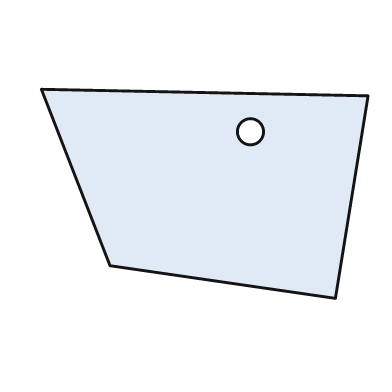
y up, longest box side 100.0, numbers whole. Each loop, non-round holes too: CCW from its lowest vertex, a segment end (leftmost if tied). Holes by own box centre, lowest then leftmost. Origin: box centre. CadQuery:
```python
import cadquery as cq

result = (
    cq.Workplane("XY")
    .moveTo(40.0, -32.0)
    .lineTo(50.0, 30.0)
    .lineTo(-50.0, 32.0)
    .lineTo(-29.0, -22.0)
    .close()
    .moveTo(14.0, 19.0)
    .circle(4.0)
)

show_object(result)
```